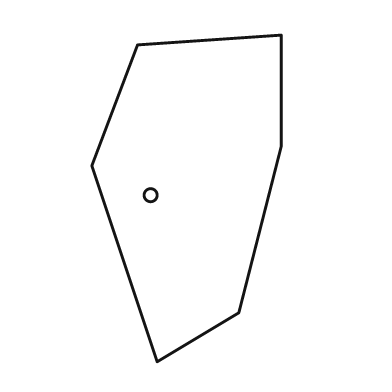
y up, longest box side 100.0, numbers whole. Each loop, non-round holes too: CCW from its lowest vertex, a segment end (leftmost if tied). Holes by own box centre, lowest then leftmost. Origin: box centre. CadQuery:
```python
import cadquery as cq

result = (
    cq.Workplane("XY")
    .moveTo(-9.0, -50.0)
    .lineTo(16.0, -35.0)
    .lineTo(29.0, 16.0)
    .lineTo(29.0, 50.0)
    .lineTo(-15.0, 47.0)
    .lineTo(-29.0, 10.0)
    .close()
    .moveTo(-11.0, 1.0)
    .circle(2.0)
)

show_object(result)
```